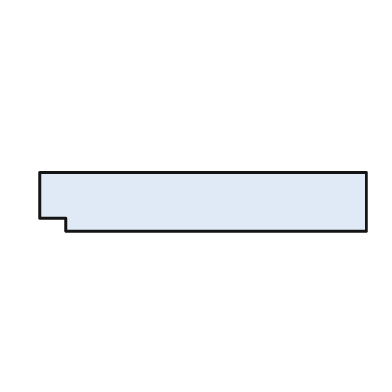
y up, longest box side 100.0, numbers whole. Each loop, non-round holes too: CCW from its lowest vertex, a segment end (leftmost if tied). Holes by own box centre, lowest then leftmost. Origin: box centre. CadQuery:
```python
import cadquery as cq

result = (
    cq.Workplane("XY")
    .moveTo(-42.0, -9.0)
    .lineTo(50.0, -9.0)
    .lineTo(50.0, 9.0)
    .lineTo(-50.0, 9.0)
    .lineTo(-50.0, -5.0)
    .lineTo(-42.0, -5.0)
    .close()
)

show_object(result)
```